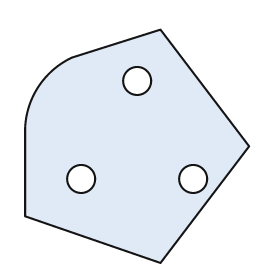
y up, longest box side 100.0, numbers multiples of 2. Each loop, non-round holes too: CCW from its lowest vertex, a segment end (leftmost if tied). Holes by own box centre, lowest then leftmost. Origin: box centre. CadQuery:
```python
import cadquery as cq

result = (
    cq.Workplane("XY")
    .moveTo(10.0, -50.0)
    .lineTo(48.0, 0.0)
    .lineTo(10.0, 50.0)
    .lineTo(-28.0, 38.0)
    .threePointArc((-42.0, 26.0), (-48.0, 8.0))
    .lineTo(-48.0, -30.0)
    .close()
    .moveTo(-24.0, -14.0)
    .circle(6.0)
    .moveTo(24.0, -14.0)
    .circle(6.0)
    .moveTo(0.0, 28.0)
    .circle(6.0)
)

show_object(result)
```